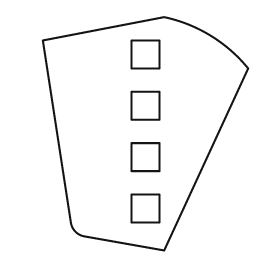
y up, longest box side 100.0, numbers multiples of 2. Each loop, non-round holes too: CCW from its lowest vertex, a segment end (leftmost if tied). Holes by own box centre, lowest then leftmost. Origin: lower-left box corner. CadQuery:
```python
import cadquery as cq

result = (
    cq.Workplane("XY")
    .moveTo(52.0, 0.0)
    .lineTo(88.0, 78.0)
    .threePointArc((72.0, 92.0), (52.0, 100.0))
    .lineTo(0.0, 90.0)
    .lineTo(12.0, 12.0)
    .threePointArc((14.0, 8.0), (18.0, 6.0))
    .close()
    .moveTo(38.0, 12.0)
    .lineTo(50.0, 12.0)
    .lineTo(50.0, 24.0)
    .lineTo(38.0, 24.0)
    .close()
    .moveTo(38.0, 34.0)
    .lineTo(50.0, 34.0)
    .lineTo(50.0, 46.0)
    .lineTo(38.0, 46.0)
    .close()
    .moveTo(38.0, 56.0)
    .lineTo(50.0, 56.0)
    .lineTo(50.0, 68.0)
    .lineTo(38.0, 68.0)
    .close()
    .moveTo(38.0, 78.0)
    .lineTo(50.0, 78.0)
    .lineTo(50.0, 90.0)
    .lineTo(38.0, 90.0)
    .close()
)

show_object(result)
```